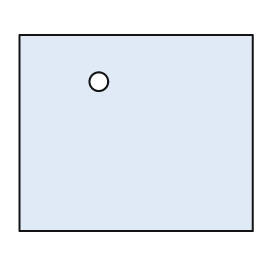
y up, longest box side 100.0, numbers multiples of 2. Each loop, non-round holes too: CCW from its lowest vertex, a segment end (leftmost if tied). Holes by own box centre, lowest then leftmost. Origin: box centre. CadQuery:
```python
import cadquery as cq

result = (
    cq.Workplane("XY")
    .moveTo(-50.0, -42.0)
    .lineTo(50.0, -42.0)
    .lineTo(50.0, 42.0)
    .lineTo(-50.0, 42.0)
    .close()
    .moveTo(-16.0, 22.0)
    .circle(4.0)
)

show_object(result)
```